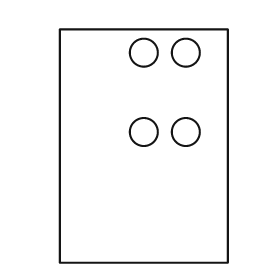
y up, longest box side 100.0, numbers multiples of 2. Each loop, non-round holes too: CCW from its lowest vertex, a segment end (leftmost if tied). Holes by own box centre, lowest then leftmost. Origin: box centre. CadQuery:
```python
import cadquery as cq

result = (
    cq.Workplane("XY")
    .moveTo(-36.0, -50.0)
    .lineTo(36.0, -50.0)
    .lineTo(36.0, 50.0)
    .lineTo(-36.0, 50.0)
    .close()
    .moveTo(0.0, 6.0)
    .circle(6.0)
    .moveTo(18.0, 6.0)
    .circle(6.0)
    .moveTo(0.0, 40.0)
    .circle(6.0)
    .moveTo(18.0, 40.0)
    .circle(6.0)
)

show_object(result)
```